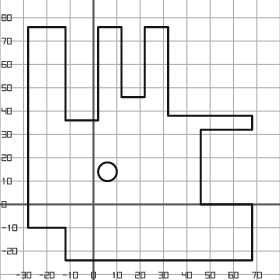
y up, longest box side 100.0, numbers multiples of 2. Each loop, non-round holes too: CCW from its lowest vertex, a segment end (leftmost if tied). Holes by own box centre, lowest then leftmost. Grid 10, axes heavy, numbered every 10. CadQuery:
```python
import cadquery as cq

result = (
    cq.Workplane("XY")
    .moveTo(-12.0, -24.0)
    .lineTo(68.0, -24.0)
    .lineTo(68.0, 0.0)
    .lineTo(46.0, 0.0)
    .lineTo(46.0, 32.0)
    .lineTo(68.0, 32.0)
    .lineTo(68.0, 38.0)
    .lineTo(32.0, 38.0)
    .lineTo(32.0, 76.0)
    .lineTo(22.0, 76.0)
    .lineTo(22.0, 46.0)
    .lineTo(12.0, 46.0)
    .lineTo(12.0, 76.0)
    .lineTo(2.0, 76.0)
    .lineTo(2.0, 36.0)
    .lineTo(-12.0, 36.0)
    .lineTo(-12.0, 76.0)
    .lineTo(-28.0, 76.0)
    .lineTo(-28.0, -10.0)
    .lineTo(-12.0, -10.0)
    .close()
    .moveTo(6.0, 14.0)
    .circle(4.0)
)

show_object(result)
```